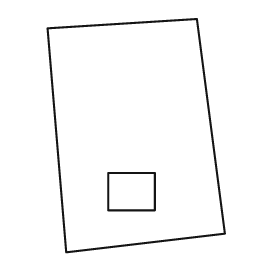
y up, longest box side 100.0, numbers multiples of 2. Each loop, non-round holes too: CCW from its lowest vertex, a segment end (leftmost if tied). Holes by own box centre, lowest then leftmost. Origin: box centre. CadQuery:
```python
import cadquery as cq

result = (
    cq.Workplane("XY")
    .moveTo(-30.0, -50.0)
    .lineTo(38.0, -42.0)
    .lineTo(26.0, 50.0)
    .lineTo(-38.0, 46.0)
    .close()
    .moveTo(-12.0, -32.0)
    .lineTo(8.0, -32.0)
    .lineTo(8.0, -16.0)
    .lineTo(-12.0, -16.0)
    .close()
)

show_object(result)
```